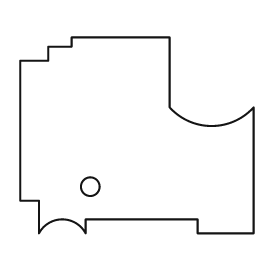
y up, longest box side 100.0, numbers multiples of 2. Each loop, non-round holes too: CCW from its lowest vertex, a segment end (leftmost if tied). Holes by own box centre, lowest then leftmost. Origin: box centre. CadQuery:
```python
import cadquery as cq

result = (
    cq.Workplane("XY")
    .moveTo(-42.0, -42.0)
    .threePointArc((-32.0, -36.0), (-22.0, -42.0))
    .lineTo(-22.0, -36.0)
    .lineTo(26.0, -36.0)
    .lineTo(26.0, -42.0)
    .lineTo(50.0, -42.0)
    .lineTo(50.0, 12.0)
    .threePointArc((32.0, 4.0), (14.0, 12.0))
    .lineTo(14.0, 42.0)
    .lineTo(-28.0, 42.0)
    .lineTo(-28.0, 38.0)
    .lineTo(-38.0, 38.0)
    .lineTo(-38.0, 32.0)
    .lineTo(-50.0, 32.0)
    .lineTo(-50.0, -28.0)
    .lineTo(-42.0, -28.0)
    .close()
    .moveTo(-20.0, -22.0)
    .circle(4.0)
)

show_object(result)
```